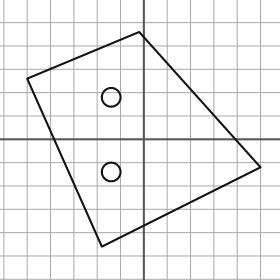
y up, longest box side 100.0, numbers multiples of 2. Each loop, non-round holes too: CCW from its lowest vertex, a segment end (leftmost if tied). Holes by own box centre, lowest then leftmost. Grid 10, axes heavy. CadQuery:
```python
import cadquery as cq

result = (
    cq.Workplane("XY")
    .moveTo(-18.0, -46.0)
    .lineTo(50.0, -12.0)
    .lineTo(-2.0, 46.0)
    .lineTo(-50.0, 26.0)
    .close()
    .moveTo(-14.0, -14.0)
    .circle(4.0)
    .moveTo(-14.0, 18.0)
    .circle(4.0)
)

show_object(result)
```